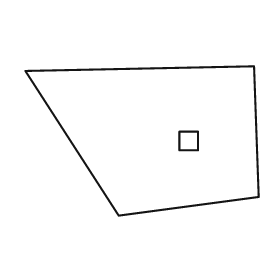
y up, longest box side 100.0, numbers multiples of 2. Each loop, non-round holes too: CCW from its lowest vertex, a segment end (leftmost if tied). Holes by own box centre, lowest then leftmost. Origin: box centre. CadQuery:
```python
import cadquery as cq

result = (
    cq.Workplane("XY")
    .moveTo(-10.0, -32.0)
    .lineTo(50.0, -24.0)
    .lineTo(48.0, 32.0)
    .lineTo(-50.0, 30.0)
    .close()
    .moveTo(16.0, -4.0)
    .lineTo(24.0, -4.0)
    .lineTo(24.0, 4.0)
    .lineTo(16.0, 4.0)
    .close()
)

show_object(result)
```